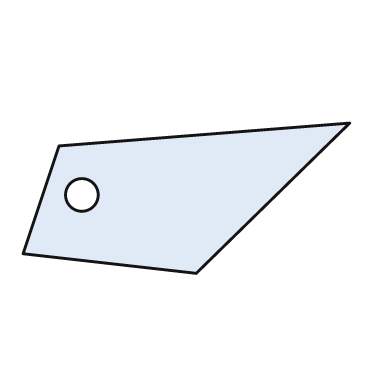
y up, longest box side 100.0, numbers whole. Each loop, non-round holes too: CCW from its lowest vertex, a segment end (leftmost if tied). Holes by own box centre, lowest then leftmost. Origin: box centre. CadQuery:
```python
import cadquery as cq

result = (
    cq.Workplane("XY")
    .moveTo(3.0, -23.0)
    .lineTo(50.0, 23.0)
    .lineTo(-39.0, 16.0)
    .lineTo(-50.0, -17.0)
    .close()
    .moveTo(-32.0, 1.0)
    .circle(5.0)
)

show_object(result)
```